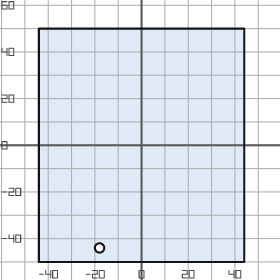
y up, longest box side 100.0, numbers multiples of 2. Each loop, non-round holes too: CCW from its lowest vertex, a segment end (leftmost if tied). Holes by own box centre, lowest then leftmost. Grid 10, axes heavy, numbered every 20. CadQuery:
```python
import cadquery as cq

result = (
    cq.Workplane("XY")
    .moveTo(-44.0, -50.0)
    .lineTo(44.0, -50.0)
    .lineTo(44.0, 50.0)
    .lineTo(-44.0, 50.0)
    .close()
    .moveTo(-18.0, -44.0)
    .circle(2.0)
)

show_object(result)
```